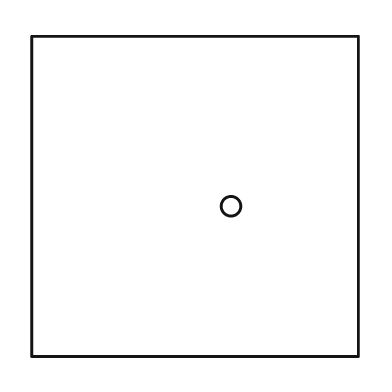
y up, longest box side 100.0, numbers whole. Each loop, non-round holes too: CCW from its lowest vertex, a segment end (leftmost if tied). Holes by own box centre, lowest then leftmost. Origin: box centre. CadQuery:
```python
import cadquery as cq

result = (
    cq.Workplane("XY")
    .moveTo(-50.0, -49.0)
    .lineTo(50.0, -49.0)
    .lineTo(50.0, 49.0)
    .lineTo(-50.0, 49.0)
    .close()
    .moveTo(11.0, -3.0)
    .circle(3.0)
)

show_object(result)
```